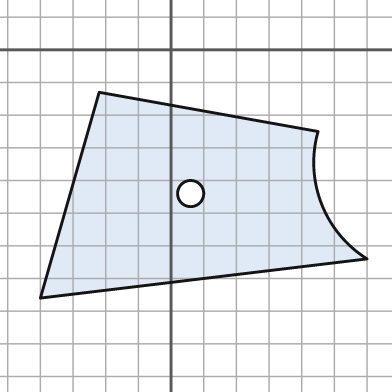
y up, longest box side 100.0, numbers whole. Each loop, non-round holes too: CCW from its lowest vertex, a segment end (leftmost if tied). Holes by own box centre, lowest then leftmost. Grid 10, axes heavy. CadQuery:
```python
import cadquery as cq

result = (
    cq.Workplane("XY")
    .moveTo(-40.0, -76.0)
    .lineTo(60.0, -64.0)
    .threePointArc((46.0, -47.0), (45.0, -25.0))
    .lineTo(-22.0, -13.0)
    .close()
    .moveTo(6.0, -44.0)
    .circle(4.0)
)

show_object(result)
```